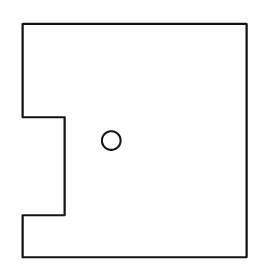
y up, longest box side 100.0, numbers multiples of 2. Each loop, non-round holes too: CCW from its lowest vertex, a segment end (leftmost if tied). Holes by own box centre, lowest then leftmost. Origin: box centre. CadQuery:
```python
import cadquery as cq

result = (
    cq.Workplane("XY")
    .moveTo(-48.0, -50.0)
    .lineTo(48.0, -50.0)
    .lineTo(48.0, 50.0)
    .lineTo(-48.0, 50.0)
    .lineTo(-48.0, 10.0)
    .lineTo(-30.0, 10.0)
    .lineTo(-30.0, -32.0)
    .lineTo(-48.0, -32.0)
    .close()
    .moveTo(-10.0, 0.0)
    .circle(4.0)
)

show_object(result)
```